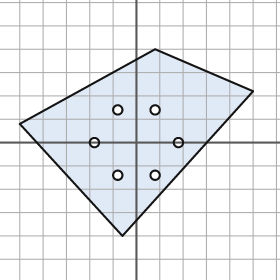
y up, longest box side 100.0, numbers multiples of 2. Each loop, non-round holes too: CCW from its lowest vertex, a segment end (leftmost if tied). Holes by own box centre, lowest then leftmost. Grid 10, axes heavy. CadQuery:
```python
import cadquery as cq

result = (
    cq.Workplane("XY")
    .moveTo(-6.0, -40.0)
    .lineTo(50.0, 22.0)
    .lineTo(8.0, 40.0)
    .lineTo(-50.0, 8.0)
    .close()
    .moveTo(-8.0, -14.0)
    .circle(2.0)
    .moveTo(8.0, -14.0)
    .circle(2.0)
    .moveTo(-18.0, 0.0)
    .circle(2.0)
    .moveTo(18.0, 0.0)
    .circle(2.0)
    .moveTo(-8.0, 14.0)
    .circle(2.0)
    .moveTo(8.0, 14.0)
    .circle(2.0)
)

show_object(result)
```